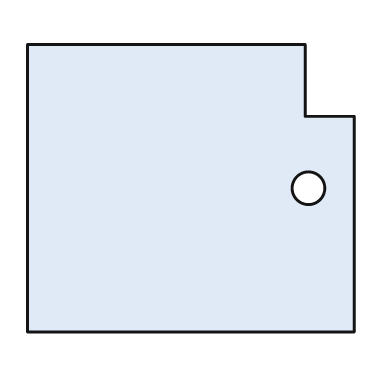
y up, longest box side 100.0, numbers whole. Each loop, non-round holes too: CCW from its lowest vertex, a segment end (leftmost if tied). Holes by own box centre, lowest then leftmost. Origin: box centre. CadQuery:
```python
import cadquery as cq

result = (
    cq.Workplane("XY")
    .moveTo(-50.0, -44.0)
    .lineTo(50.0, -44.0)
    .lineTo(50.0, 22.0)
    .lineTo(35.0, 22.0)
    .lineTo(35.0, 44.0)
    .lineTo(-50.0, 44.0)
    .close()
    .moveTo(36.0, 0.0)
    .circle(5.0)
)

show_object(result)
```